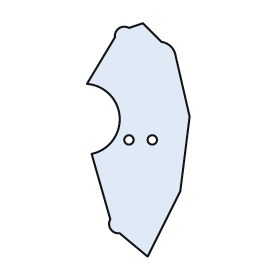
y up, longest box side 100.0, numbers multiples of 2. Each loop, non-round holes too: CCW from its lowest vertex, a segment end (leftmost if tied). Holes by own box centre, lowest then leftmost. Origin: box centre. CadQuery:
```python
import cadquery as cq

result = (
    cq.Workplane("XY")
    .moveTo(4.0, -50.0)
    .lineTo(18.0, -22.0)
    .lineTo(22.0, 10.0)
    .lineTo(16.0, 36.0)
    .threePointArc((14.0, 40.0), (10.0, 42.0))
    .lineTo(2.0, 50.0)
    .lineTo(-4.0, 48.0)
    .threePointArc((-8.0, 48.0), (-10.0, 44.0))
    .lineTo(-22.0, 24.0)
    .threePointArc((-8.0, 10.0), (-20.0, -6.0))
    .lineTo(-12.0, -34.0)
    .threePointArc((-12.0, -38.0), (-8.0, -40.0))
    .close()
    .moveTo(-4.0, 0.0)
    .circle(2.0)
    .moveTo(6.0, 0.0)
    .circle(2.0)
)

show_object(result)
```